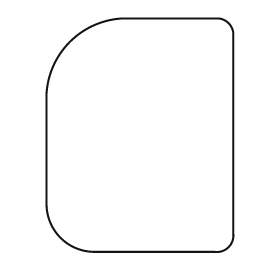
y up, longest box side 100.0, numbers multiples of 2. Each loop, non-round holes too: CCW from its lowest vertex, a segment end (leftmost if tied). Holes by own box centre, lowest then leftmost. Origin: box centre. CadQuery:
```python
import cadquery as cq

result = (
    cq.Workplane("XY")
    .moveTo(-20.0, -50.0)
    .lineTo(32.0, -50.0)
    .threePointArc((38.0, -48.0), (40.0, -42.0))
    .lineTo(40.0, 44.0)
    .threePointArc((38.0, 48.0), (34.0, 50.0))
    .lineTo(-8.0, 50.0)
    .threePointArc((-30.0, 40.0), (-40.0, 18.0))
    .lineTo(-40.0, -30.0)
    .threePointArc((-34.0, -44.0), (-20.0, -50.0))
    .close()
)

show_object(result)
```